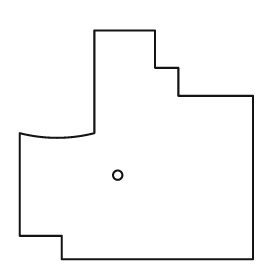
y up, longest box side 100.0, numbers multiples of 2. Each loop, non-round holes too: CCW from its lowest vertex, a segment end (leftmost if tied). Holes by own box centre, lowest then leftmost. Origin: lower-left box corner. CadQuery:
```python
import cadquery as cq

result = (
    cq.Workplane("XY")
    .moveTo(18.0, 0.0)
    .lineTo(100.0, 0.0)
    .lineTo(100.0, 70.0)
    .lineTo(68.0, 70.0)
    .lineTo(68.0, 82.0)
    .lineTo(58.0, 82.0)
    .lineTo(58.0, 98.0)
    .lineTo(32.0, 98.0)
    .lineTo(32.0, 54.0)
    .threePointArc((16.0, 52.0), (0.0, 54.0))
    .lineTo(0.0, 10.0)
    .lineTo(18.0, 10.0)
    .close()
    .moveTo(42.0, 36.0)
    .circle(2.0)
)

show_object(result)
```